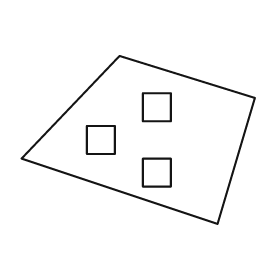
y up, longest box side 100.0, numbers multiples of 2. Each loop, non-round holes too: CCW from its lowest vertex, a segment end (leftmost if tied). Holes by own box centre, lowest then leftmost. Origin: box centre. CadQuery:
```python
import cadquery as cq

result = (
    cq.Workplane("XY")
    .moveTo(34.0, -36.0)
    .lineTo(50.0, 18.0)
    .lineTo(-8.0, 36.0)
    .lineTo(-50.0, -8.0)
    .close()
    .moveTo(2.0, -20.0)
    .lineTo(14.0, -20.0)
    .lineTo(14.0, -8.0)
    .lineTo(2.0, -8.0)
    .close()
    .moveTo(-22.0, -6.0)
    .lineTo(-10.0, -6.0)
    .lineTo(-10.0, 6.0)
    .lineTo(-22.0, 6.0)
    .close()
    .moveTo(2.0, 8.0)
    .lineTo(14.0, 8.0)
    .lineTo(14.0, 20.0)
    .lineTo(2.0, 20.0)
    .close()
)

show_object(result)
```